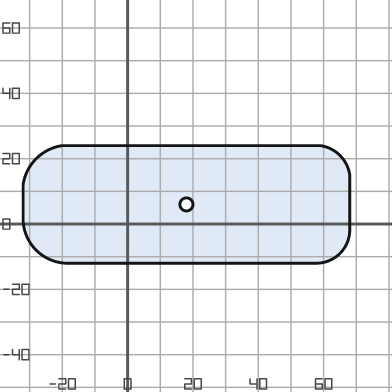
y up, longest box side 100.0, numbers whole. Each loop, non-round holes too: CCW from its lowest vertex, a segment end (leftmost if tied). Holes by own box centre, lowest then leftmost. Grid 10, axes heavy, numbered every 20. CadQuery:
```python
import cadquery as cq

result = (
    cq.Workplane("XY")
    .moveTo(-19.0, -12.0)
    .lineTo(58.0, -12.0)
    .threePointArc((65.0, -9.0), (68.0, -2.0))
    .lineTo(68.0, 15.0)
    .threePointArc((65.0, 21.0), (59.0, 24.0))
    .lineTo(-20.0, 24.0)
    .threePointArc((-28.0, 20.0), (-32.0, 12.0))
    .lineTo(-32.0, 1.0)
    .threePointArc((-28.0, -8.0), (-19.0, -12.0))
    .close()
    .moveTo(18.0, 6.0)
    .circle(2.0)
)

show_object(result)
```